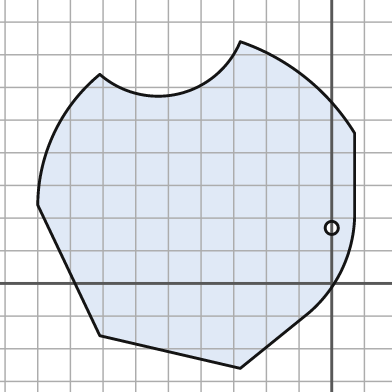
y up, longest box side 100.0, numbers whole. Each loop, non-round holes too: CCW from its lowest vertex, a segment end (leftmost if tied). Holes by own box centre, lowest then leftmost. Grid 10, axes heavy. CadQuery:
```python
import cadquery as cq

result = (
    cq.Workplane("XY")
    .moveTo(-28.0, -26.0)
    .lineTo(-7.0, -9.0)
    .threePointArc((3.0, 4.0), (7.0, 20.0))
    .lineTo(7.0, 46.0)
    .threePointArc((-8.0, 63.0), (-28.0, 74.0))
    .threePointArc((-47.0, 58.0), (-71.0, 64.0))
    .threePointArc((-85.0, 46.0), (-90.0, 24.0))
    .lineTo(-71.0, -16.0)
    .close()
    .moveTo(0.0, 17.0)
    .circle(2.0)
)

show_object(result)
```